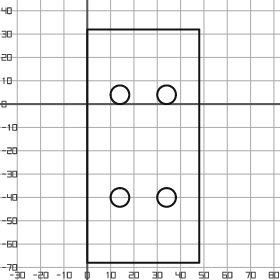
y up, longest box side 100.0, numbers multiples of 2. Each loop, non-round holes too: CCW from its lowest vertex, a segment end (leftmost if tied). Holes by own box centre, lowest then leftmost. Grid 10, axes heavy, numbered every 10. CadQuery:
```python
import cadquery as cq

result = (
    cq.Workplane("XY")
    .moveTo(0.0, -68.0)
    .lineTo(48.0, -68.0)
    .lineTo(48.0, 32.0)
    .lineTo(0.0, 32.0)
    .close()
    .moveTo(14.0, -40.0)
    .circle(4.0)
    .moveTo(34.0, -40.0)
    .circle(4.0)
    .moveTo(14.0, 4.0)
    .circle(4.0)
    .moveTo(34.0, 4.0)
    .circle(4.0)
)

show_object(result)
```